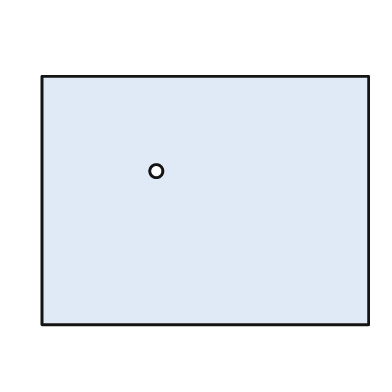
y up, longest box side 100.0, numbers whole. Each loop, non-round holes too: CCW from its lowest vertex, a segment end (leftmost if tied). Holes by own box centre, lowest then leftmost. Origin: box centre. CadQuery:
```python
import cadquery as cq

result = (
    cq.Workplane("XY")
    .moveTo(-50.0, -38.0)
    .lineTo(50.0, -38.0)
    .lineTo(50.0, 38.0)
    .lineTo(-50.0, 38.0)
    .close()
    .moveTo(-15.0, 9.0)
    .circle(2.0)
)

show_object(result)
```